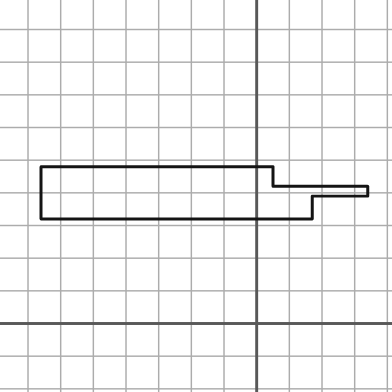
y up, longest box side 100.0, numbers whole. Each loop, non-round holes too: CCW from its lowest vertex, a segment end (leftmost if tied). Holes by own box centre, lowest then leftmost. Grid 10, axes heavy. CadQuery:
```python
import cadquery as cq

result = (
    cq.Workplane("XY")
    .moveTo(-66.0, 32.0)
    .lineTo(17.0, 32.0)
    .lineTo(17.0, 39.0)
    .lineTo(34.0, 39.0)
    .lineTo(34.0, 42.0)
    .lineTo(5.0, 42.0)
    .lineTo(5.0, 48.0)
    .lineTo(-66.0, 48.0)
    .close()
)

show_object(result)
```